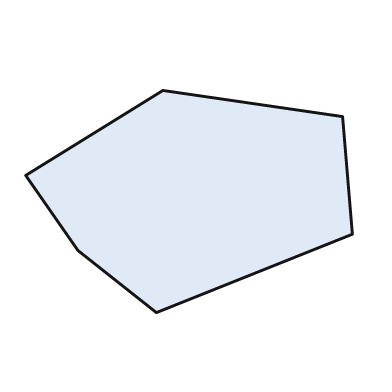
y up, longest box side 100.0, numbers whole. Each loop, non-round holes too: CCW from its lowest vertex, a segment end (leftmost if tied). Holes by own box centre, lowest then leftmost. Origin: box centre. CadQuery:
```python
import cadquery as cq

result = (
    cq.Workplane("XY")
    .moveTo(-10.0, -34.0)
    .lineTo(50.0, -10.0)
    .lineTo(47.0, 26.0)
    .lineTo(-8.0, 34.0)
    .lineTo(-50.0, 8.0)
    .lineTo(-34.0, -15.0)
    .close()
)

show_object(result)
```